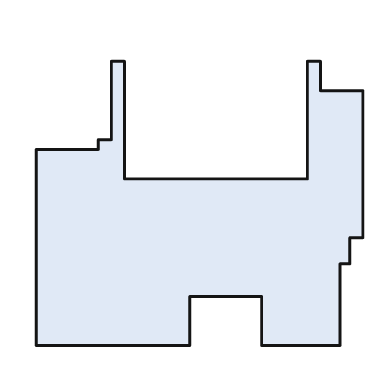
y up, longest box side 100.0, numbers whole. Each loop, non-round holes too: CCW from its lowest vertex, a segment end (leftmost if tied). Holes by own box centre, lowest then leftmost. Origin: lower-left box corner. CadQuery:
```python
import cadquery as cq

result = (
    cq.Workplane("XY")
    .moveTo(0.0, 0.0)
    .lineTo(47.0, 0.0)
    .lineTo(47.0, 15.0)
    .lineTo(69.0, 15.0)
    .lineTo(69.0, 0.0)
    .lineTo(93.0, 0.0)
    .lineTo(93.0, 25.0)
    .lineTo(96.0, 25.0)
    .lineTo(96.0, 33.0)
    .lineTo(100.0, 33.0)
    .lineTo(100.0, 78.0)
    .lineTo(87.0, 78.0)
    .lineTo(87.0, 87.0)
    .lineTo(83.0, 87.0)
    .lineTo(83.0, 51.0)
    .lineTo(27.0, 51.0)
    .lineTo(27.0, 87.0)
    .lineTo(23.0, 87.0)
    .lineTo(23.0, 63.0)
    .lineTo(19.0, 63.0)
    .lineTo(19.0, 60.0)
    .lineTo(0.0, 60.0)
    .close()
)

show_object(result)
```